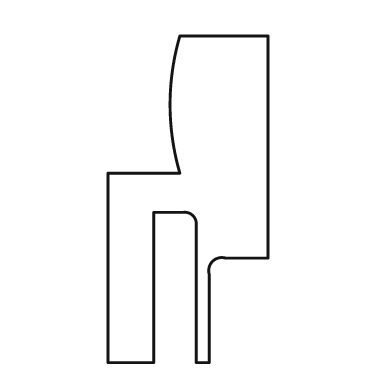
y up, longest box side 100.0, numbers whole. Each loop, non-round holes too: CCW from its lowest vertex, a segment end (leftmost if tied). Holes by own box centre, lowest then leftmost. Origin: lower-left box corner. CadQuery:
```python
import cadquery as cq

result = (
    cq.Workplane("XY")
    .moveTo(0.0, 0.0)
    .lineTo(14.0, 0.0)
    .lineTo(14.0, 46.0)
    .lineTo(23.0, 46.0)
    .threePointArc((26.0, 45.0), (27.0, 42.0))
    .lineTo(27.0, 0.0)
    .lineTo(31.0, 0.0)
    .lineTo(31.0, 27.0)
    .threePointArc((32.0, 31.0), (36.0, 32.0))
    .lineTo(49.0, 32.0)
    .lineTo(49.0, 100.0)
    .lineTo(22.0, 100.0)
    .threePointArc((19.0, 79.0), (22.0, 58.0))
    .lineTo(0.0, 58.0)
    .close()
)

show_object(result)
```